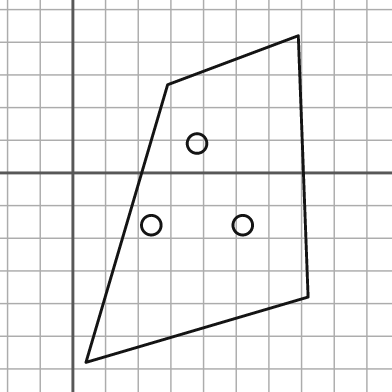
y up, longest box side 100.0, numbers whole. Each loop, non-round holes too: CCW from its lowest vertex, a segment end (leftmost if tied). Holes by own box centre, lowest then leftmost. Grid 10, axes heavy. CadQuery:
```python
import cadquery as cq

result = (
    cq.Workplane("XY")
    .moveTo(4.0, -58.0)
    .lineTo(72.0, -38.0)
    .lineTo(69.0, 42.0)
    .lineTo(29.0, 27.0)
    .close()
    .moveTo(24.0, -16.0)
    .circle(3.0)
    .moveTo(52.0, -16.0)
    .circle(3.0)
    .moveTo(38.0, 9.0)
    .circle(3.0)
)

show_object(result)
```